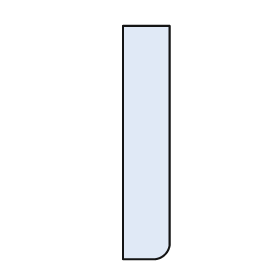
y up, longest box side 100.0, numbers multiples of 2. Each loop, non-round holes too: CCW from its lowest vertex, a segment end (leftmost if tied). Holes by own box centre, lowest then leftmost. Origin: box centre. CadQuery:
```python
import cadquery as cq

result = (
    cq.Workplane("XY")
    .moveTo(-10.0, -50.0)
    .lineTo(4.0, -50.0)
    .threePointArc((8.0, -48.0), (10.0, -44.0))
    .lineTo(10.0, 50.0)
    .lineTo(-10.0, 50.0)
    .close()
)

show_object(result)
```